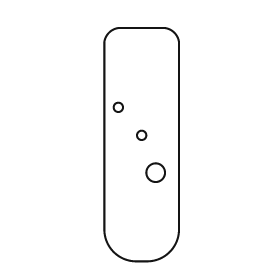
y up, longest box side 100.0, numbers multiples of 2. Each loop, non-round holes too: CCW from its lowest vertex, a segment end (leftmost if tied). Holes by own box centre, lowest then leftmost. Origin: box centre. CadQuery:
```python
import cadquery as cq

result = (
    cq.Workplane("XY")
    .moveTo(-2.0, -50.0)
    .lineTo(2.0, -50.0)
    .threePointArc((12.0, -46.0), (16.0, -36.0))
    .lineTo(16.0, 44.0)
    .threePointArc((14.0, 48.0), (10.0, 50.0))
    .lineTo(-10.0, 50.0)
    .threePointArc((-14.0, 48.0), (-16.0, 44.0))
    .lineTo(-16.0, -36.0)
    .threePointArc((-12.0, -46.0), (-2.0, -50.0))
    .close()
    .moveTo(6.0, -12.0)
    .circle(4.0)
    .moveTo(0.0, 4.0)
    .circle(2.0)
    .moveTo(-10.0, 16.0)
    .circle(2.0)
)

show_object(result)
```